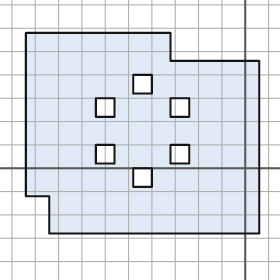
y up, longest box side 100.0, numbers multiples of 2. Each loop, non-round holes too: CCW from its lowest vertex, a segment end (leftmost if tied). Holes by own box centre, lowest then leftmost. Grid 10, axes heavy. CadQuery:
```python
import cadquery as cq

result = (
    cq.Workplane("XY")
    .moveTo(-84.0, -28.0)
    .lineTo(6.0, -28.0)
    .lineTo(6.0, 46.0)
    .lineTo(-32.0, 46.0)
    .lineTo(-32.0, 58.0)
    .lineTo(-94.0, 58.0)
    .lineTo(-94.0, -12.0)
    .lineTo(-84.0, -12.0)
    .close()
    .moveTo(-48.0, -8.0)
    .lineTo(-40.0, -8.0)
    .lineTo(-40.0, 0.0)
    .lineTo(-48.0, 0.0)
    .close()
    .moveTo(-64.0, 2.0)
    .lineTo(-56.0, 2.0)
    .lineTo(-56.0, 10.0)
    .lineTo(-64.0, 10.0)
    .close()
    .moveTo(-32.0, 2.0)
    .lineTo(-24.0, 2.0)
    .lineTo(-24.0, 10.0)
    .lineTo(-32.0, 10.0)
    .close()
    .moveTo(-64.0, 22.0)
    .lineTo(-56.0, 22.0)
    .lineTo(-56.0, 30.0)
    .lineTo(-64.0, 30.0)
    .close()
    .moveTo(-32.0, 22.0)
    .lineTo(-24.0, 22.0)
    .lineTo(-24.0, 30.0)
    .lineTo(-32.0, 30.0)
    .close()
    .moveTo(-48.0, 32.0)
    .lineTo(-40.0, 32.0)
    .lineTo(-40.0, 40.0)
    .lineTo(-48.0, 40.0)
    .close()
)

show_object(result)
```